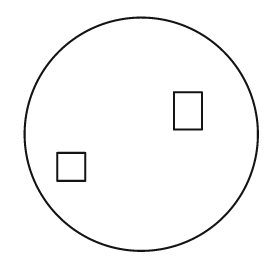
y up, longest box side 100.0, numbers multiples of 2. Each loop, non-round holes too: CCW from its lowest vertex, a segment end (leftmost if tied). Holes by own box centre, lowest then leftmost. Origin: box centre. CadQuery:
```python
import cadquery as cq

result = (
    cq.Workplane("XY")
    .moveTo(0.0, 0.0)
    .circle(50.0)
    .moveTo(-36.0, -20.0)
    .lineTo(-24.0, -20.0)
    .lineTo(-24.0, -8.0)
    .lineTo(-36.0, -8.0)
    .close()
    .moveTo(14.0, 2.0)
    .lineTo(26.0, 2.0)
    .lineTo(26.0, 18.0)
    .lineTo(14.0, 18.0)
    .close()
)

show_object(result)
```